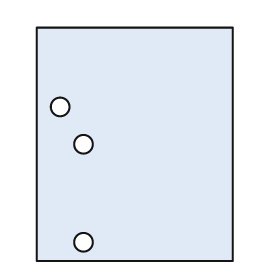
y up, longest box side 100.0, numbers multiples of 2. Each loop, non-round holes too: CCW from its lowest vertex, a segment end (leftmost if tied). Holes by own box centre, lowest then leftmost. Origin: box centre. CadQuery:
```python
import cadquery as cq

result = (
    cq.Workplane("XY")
    .moveTo(-42.0, -50.0)
    .lineTo(42.0, -50.0)
    .lineTo(42.0, 50.0)
    .lineTo(-42.0, 50.0)
    .close()
    .moveTo(-22.0, -42.0)
    .circle(4.0)
    .moveTo(-22.0, 0.0)
    .circle(4.0)
    .moveTo(-32.0, 16.0)
    .circle(4.0)
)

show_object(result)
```